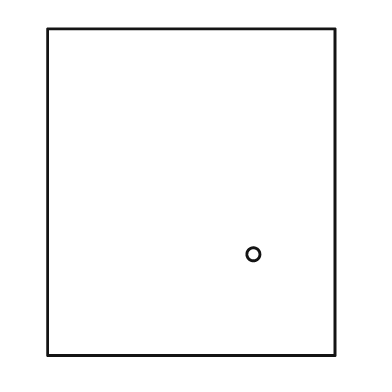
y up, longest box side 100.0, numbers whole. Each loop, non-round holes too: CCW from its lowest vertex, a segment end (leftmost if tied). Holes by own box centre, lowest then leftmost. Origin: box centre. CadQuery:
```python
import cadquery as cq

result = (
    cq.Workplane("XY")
    .moveTo(-44.0, -50.0)
    .lineTo(44.0, -50.0)
    .lineTo(44.0, 50.0)
    .lineTo(-44.0, 50.0)
    .close()
    .moveTo(19.0, -19.0)
    .circle(2.0)
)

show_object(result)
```